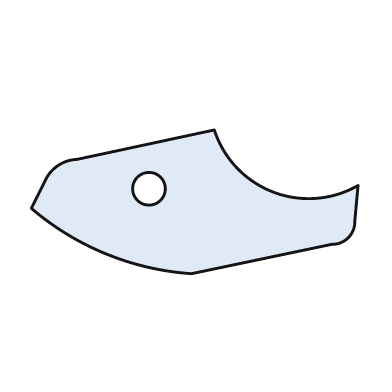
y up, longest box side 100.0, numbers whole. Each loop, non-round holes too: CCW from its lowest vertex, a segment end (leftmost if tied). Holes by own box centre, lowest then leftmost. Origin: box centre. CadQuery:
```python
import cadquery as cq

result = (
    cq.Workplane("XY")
    .moveTo(-1.0, -22.0)
    .lineTo(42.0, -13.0)
    .threePointArc((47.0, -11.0), (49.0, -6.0))
    .lineTo(50.0, 5.0)
    .threePointArc((24.0, 3.0), (6.0, 22.0))
    .lineTo(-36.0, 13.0)
    .threePointArc((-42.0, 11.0), (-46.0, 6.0))
    .lineTo(-50.0, -2.0)
    .threePointArc((-27.0, -16.0), (-1.0, -22.0))
    .close()
    .moveTo(-14.0, 4.0)
    .circle(5.0)
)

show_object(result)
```